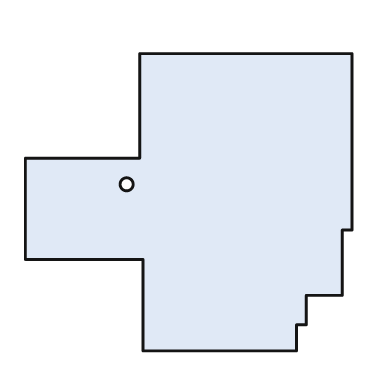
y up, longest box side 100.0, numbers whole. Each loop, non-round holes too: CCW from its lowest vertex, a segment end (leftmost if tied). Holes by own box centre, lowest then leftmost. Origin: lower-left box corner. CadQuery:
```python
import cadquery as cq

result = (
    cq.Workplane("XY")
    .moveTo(36.0, 0.0)
    .lineTo(83.0, 0.0)
    .lineTo(83.0, 8.0)
    .lineTo(86.0, 8.0)
    .lineTo(86.0, 17.0)
    .lineTo(97.0, 17.0)
    .lineTo(97.0, 37.0)
    .lineTo(100.0, 37.0)
    .lineTo(100.0, 91.0)
    .lineTo(35.0, 91.0)
    .lineTo(35.0, 59.0)
    .lineTo(0.0, 59.0)
    .lineTo(0.0, 28.0)
    .lineTo(36.0, 28.0)
    .close()
    .moveTo(31.0, 51.0)
    .circle(2.0)
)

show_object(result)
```